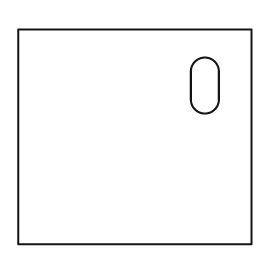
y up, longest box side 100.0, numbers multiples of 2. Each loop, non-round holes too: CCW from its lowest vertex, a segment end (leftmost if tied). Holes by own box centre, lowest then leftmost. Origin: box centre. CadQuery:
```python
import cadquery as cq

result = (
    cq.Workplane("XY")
    .moveTo(-50.0, -46.0)
    .lineTo(50.0, -46.0)
    .lineTo(50.0, 46.0)
    .lineTo(-50.0, 46.0)
    .close()
    .moveTo(24.0, 16.0)
    .threePointArc((30.0, 10.0), (36.0, 16.0))
    .lineTo(36.0, 28.0)
    .threePointArc((30.0, 34.0), (24.0, 28.0))
    .close()
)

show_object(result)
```